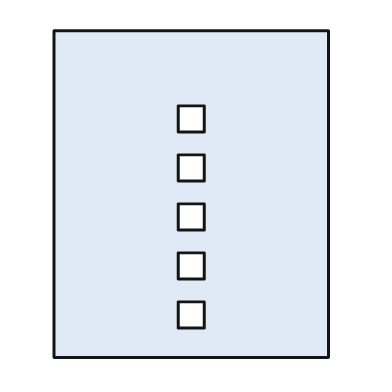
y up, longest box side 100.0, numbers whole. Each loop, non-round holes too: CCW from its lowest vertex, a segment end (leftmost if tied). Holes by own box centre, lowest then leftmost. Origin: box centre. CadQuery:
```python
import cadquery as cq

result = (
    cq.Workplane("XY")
    .moveTo(-42.0, -50.0)
    .lineTo(42.0, -50.0)
    .lineTo(42.0, 50.0)
    .lineTo(-42.0, 50.0)
    .close()
    .moveTo(-4.0, -41.0)
    .lineTo(4.0, -41.0)
    .lineTo(4.0, -33.0)
    .lineTo(-4.0, -33.0)
    .close()
    .moveTo(-4.0, -26.0)
    .lineTo(4.0, -26.0)
    .lineTo(4.0, -18.0)
    .lineTo(-4.0, -18.0)
    .close()
    .moveTo(-4.0, -11.0)
    .lineTo(4.0, -11.0)
    .lineTo(4.0, -3.0)
    .lineTo(-4.0, -3.0)
    .close()
    .moveTo(-4.0, 4.0)
    .lineTo(4.0, 4.0)
    .lineTo(4.0, 12.0)
    .lineTo(-4.0, 12.0)
    .close()
    .moveTo(-4.0, 19.0)
    .lineTo(4.0, 19.0)
    .lineTo(4.0, 27.0)
    .lineTo(-4.0, 27.0)
    .close()
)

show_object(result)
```